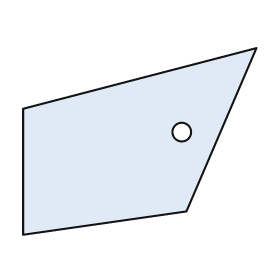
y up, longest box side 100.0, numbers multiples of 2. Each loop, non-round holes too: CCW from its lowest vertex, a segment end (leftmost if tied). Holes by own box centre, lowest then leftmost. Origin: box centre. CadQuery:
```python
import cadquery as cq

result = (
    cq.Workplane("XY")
    .moveTo(-50.0, -40.0)
    .lineTo(20.0, -30.0)
    .lineTo(50.0, 40.0)
    .lineTo(-50.0, 14.0)
    .close()
    .moveTo(18.0, 4.0)
    .circle(4.0)
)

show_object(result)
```